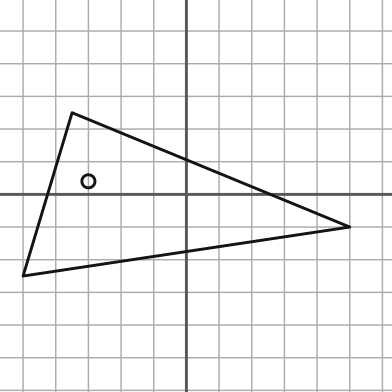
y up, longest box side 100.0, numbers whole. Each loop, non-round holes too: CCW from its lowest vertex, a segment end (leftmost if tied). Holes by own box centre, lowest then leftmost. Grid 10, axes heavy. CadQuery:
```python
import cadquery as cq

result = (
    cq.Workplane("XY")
    .moveTo(-50.0, -25.0)
    .lineTo(50.0, -10.0)
    .lineTo(-35.0, 25.0)
    .close()
    .moveTo(-30.0, 4.0)
    .circle(2.0)
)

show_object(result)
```